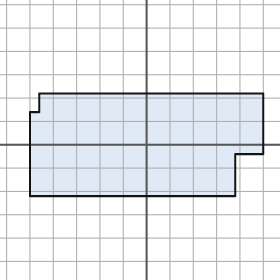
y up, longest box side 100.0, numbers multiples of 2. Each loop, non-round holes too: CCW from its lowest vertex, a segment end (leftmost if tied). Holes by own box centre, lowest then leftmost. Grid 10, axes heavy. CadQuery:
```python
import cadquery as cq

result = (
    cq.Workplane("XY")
    .moveTo(-50.0, -22.0)
    .lineTo(38.0, -22.0)
    .lineTo(38.0, -4.0)
    .lineTo(50.0, -4.0)
    .lineTo(50.0, 22.0)
    .lineTo(-46.0, 22.0)
    .lineTo(-46.0, 14.0)
    .lineTo(-50.0, 14.0)
    .close()
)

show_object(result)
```